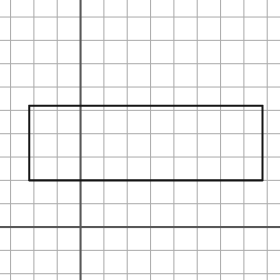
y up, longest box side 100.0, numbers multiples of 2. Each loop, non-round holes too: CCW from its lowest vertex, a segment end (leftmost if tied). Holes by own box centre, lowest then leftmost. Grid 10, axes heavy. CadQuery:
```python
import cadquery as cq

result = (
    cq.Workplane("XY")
    .moveTo(-22.0, 20.0)
    .lineTo(78.0, 20.0)
    .lineTo(78.0, 52.0)
    .lineTo(-22.0, 52.0)
    .close()
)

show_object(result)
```